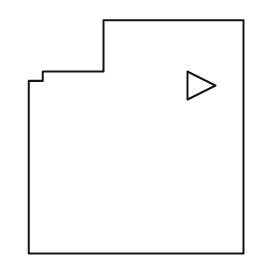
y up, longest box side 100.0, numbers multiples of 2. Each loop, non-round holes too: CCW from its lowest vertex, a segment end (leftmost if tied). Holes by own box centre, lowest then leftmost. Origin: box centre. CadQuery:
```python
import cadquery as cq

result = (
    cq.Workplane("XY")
    .moveTo(-46.0, -50.0)
    .lineTo(46.0, -50.0)
    .lineTo(46.0, 50.0)
    .lineTo(-14.0, 50.0)
    .lineTo(-14.0, 28.0)
    .lineTo(-40.0, 28.0)
    .lineTo(-40.0, 24.0)
    .lineTo(-46.0, 24.0)
    .close()
    .moveTo(22.0, 16.0)
    .lineTo(34.0, 22.0)
    .lineTo(22.0, 28.0)
    .close()
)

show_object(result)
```